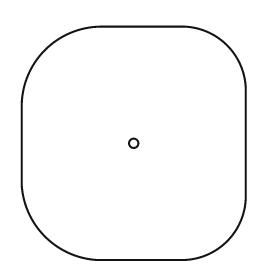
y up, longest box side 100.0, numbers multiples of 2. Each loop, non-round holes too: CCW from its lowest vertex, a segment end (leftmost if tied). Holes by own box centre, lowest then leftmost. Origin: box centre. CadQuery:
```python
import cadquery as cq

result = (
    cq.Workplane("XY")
    .moveTo(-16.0, -50.0)
    .lineTo(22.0, -50.0)
    .threePointArc((40.0, -42.0), (48.0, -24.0))
    .lineTo(48.0, 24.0)
    .threePointArc((40.0, 42.0), (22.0, 50.0))
    .lineTo(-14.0, 50.0)
    .threePointArc((-38.0, 40.0), (-48.0, 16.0))
    .lineTo(-48.0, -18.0)
    .threePointArc((-38.0, -40.0), (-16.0, -50.0))
    .close()
    .moveTo(0.0, 0.0)
    .circle(2.0)
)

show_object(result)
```